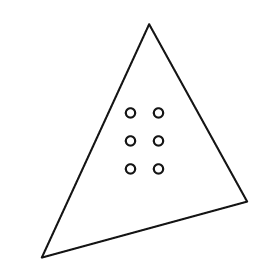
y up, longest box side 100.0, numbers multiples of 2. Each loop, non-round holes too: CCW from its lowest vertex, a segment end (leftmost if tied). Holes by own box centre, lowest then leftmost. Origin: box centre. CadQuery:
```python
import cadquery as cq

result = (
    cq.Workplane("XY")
    .moveTo(-44.0, -50.0)
    .lineTo(44.0, -26.0)
    .lineTo(2.0, 50.0)
    .close()
    .moveTo(-6.0, -12.0)
    .circle(2.0)
    .moveTo(6.0, -12.0)
    .circle(2.0)
    .moveTo(-6.0, 0.0)
    .circle(2.0)
    .moveTo(6.0, 0.0)
    .circle(2.0)
    .moveTo(-6.0, 12.0)
    .circle(2.0)
    .moveTo(6.0, 12.0)
    .circle(2.0)
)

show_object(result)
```